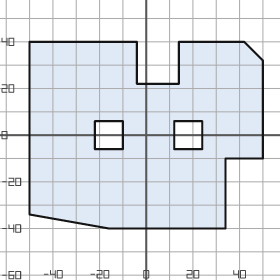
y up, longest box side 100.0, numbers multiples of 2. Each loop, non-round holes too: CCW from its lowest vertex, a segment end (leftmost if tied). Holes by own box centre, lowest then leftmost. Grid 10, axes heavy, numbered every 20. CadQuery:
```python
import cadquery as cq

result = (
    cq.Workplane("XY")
    .moveTo(-16.0, -40.0)
    .lineTo(34.0, -40.0)
    .lineTo(34.0, -10.0)
    .lineTo(50.0, -10.0)
    .lineTo(50.0, 32.0)
    .lineTo(42.0, 40.0)
    .lineTo(14.0, 40.0)
    .lineTo(14.0, 22.0)
    .lineTo(-4.0, 22.0)
    .lineTo(-4.0, 40.0)
    .lineTo(-50.0, 40.0)
    .lineTo(-50.0, -34.0)
    .close()
    .moveTo(-22.0, -6.0)
    .lineTo(-10.0, -6.0)
    .lineTo(-10.0, 6.0)
    .lineTo(-22.0, 6.0)
    .close()
    .moveTo(12.0, -6.0)
    .lineTo(24.0, -6.0)
    .lineTo(24.0, 6.0)
    .lineTo(12.0, 6.0)
    .close()
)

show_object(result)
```